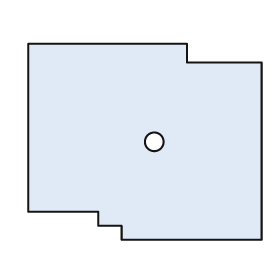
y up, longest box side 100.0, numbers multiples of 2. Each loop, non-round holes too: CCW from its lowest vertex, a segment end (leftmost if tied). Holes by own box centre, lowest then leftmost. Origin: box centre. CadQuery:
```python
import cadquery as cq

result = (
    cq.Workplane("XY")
    .moveTo(-10.0, -42.0)
    .lineTo(50.0, -42.0)
    .lineTo(50.0, 34.0)
    .lineTo(18.0, 34.0)
    .lineTo(18.0, 42.0)
    .lineTo(-50.0, 42.0)
    .lineTo(-50.0, -30.0)
    .lineTo(-20.0, -30.0)
    .lineTo(-20.0, -36.0)
    .lineTo(-10.0, -36.0)
    .close()
    .moveTo(4.0, 0.0)
    .circle(4.0)
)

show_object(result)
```